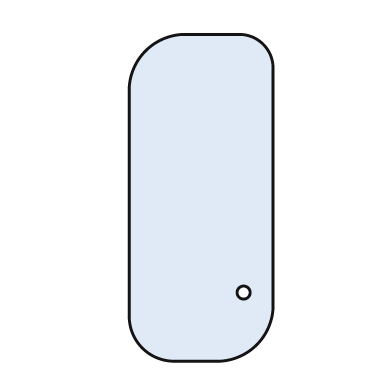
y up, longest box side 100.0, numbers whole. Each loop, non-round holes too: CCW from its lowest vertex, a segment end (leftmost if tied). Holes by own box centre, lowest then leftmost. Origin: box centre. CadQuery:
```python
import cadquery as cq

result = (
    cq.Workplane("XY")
    .moveTo(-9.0, -50.0)
    .lineTo(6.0, -50.0)
    .threePointArc((17.0, -45.0), (22.0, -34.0))
    .lineTo(22.0, 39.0)
    .threePointArc((19.0, 47.0), (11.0, 50.0))
    .lineTo(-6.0, 50.0)
    .threePointArc((-17.0, 45.0), (-22.0, 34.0))
    .lineTo(-22.0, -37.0)
    .threePointArc((-18.0, -46.0), (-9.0, -50.0))
    .close()
    .moveTo(13.0, -29.0)
    .circle(2.0)
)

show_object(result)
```